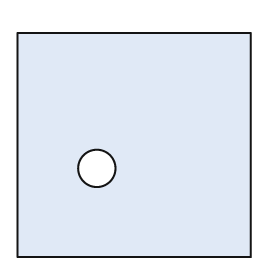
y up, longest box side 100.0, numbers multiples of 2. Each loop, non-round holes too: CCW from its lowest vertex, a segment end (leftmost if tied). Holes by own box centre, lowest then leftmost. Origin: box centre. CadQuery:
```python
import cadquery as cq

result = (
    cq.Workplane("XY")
    .moveTo(-50.0, -48.0)
    .lineTo(50.0, -48.0)
    .lineTo(50.0, 48.0)
    .lineTo(-50.0, 48.0)
    .close()
    .moveTo(-16.0, -10.0)
    .circle(8.0)
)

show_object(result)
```